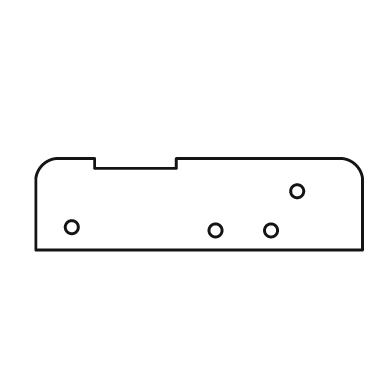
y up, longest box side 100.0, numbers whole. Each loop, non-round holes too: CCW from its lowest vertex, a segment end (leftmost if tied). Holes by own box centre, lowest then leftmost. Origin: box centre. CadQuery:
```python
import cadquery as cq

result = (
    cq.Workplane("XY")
    .moveTo(-50.0, -14.0)
    .lineTo(50.0, -14.0)
    .lineTo(50.0, 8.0)
    .threePointArc((48.0, 12.0), (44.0, 14.0))
    .lineTo(-7.0, 14.0)
    .lineTo(-7.0, 11.0)
    .lineTo(-32.0, 11.0)
    .lineTo(-32.0, 14.0)
    .lineTo(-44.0, 14.0)
    .threePointArc((-48.0, 12.0), (-50.0, 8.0))
    .close()
    .moveTo(5.0, -8.0)
    .circle(2.0)
    .moveTo(22.0, -8.0)
    .circle(2.0)
    .moveTo(-39.0, -7.0)
    .circle(2.0)
    .moveTo(30.0, 4.0)
    .circle(2.0)
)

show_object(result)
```